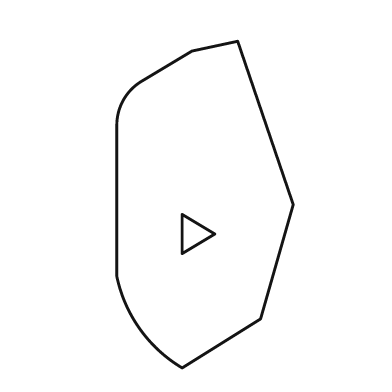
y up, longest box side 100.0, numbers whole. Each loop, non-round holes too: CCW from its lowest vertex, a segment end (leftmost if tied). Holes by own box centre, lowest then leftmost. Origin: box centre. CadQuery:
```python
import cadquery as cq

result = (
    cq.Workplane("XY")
    .moveTo(-7.0, -50.0)
    .lineTo(17.0, -35.0)
    .lineTo(27.0, 0.0)
    .lineTo(10.0, 50.0)
    .lineTo(-4.0, 47.0)
    .lineTo(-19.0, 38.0)
    .threePointArc((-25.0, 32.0), (-27.0, 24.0))
    .lineTo(-27.0, -22.0)
    .threePointArc((-20.0, -38.0), (-7.0, -50.0))
    .close()
    .moveTo(-7.0, -15.0)
    .lineTo(3.0, -9.0)
    .lineTo(-7.0, -3.0)
    .close()
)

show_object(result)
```